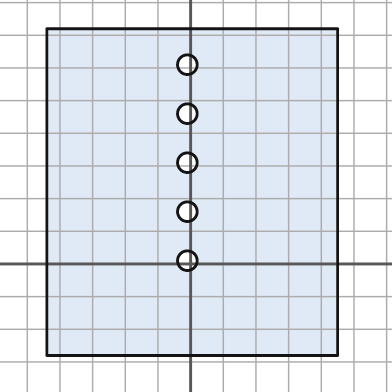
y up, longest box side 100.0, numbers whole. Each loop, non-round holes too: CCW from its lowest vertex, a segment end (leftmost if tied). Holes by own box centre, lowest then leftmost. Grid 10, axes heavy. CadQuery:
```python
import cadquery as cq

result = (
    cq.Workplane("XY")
    .moveTo(-44.0, -28.0)
    .lineTo(45.0, -28.0)
    .lineTo(45.0, 72.0)
    .lineTo(-44.0, 72.0)
    .close()
    .moveTo(-1.0, 1.0)
    .circle(3.0)
    .moveTo(-1.0, 16.0)
    .circle(3.0)
    .moveTo(-1.0, 31.0)
    .circle(3.0)
    .moveTo(-1.0, 46.0)
    .circle(3.0)
    .moveTo(-1.0, 61.0)
    .circle(3.0)
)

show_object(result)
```